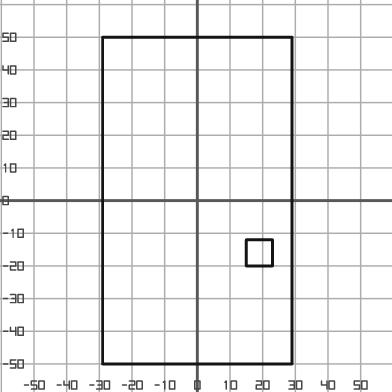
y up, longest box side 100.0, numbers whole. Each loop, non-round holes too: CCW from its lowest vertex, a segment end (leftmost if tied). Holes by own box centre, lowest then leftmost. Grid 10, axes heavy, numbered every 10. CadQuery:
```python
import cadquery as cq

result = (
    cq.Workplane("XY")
    .moveTo(-29.0, -50.0)
    .lineTo(29.0, -50.0)
    .lineTo(29.0, 50.0)
    .lineTo(-29.0, 50.0)
    .close()
    .moveTo(15.0, -20.0)
    .lineTo(23.0, -20.0)
    .lineTo(23.0, -12.0)
    .lineTo(15.0, -12.0)
    .close()
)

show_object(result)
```